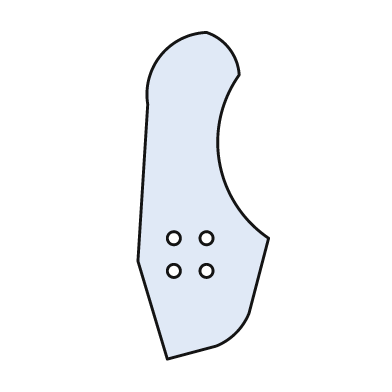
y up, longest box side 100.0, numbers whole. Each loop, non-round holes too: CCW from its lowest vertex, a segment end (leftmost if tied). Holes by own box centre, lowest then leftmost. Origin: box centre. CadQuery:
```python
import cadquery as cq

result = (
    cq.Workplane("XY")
    .moveTo(-11.0, -50.0)
    .lineTo(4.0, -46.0)
    .threePointArc((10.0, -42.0), (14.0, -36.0))
    .lineTo(20.0, -13.0)
    .threePointArc((5.0, 10.0), (11.0, 37.0))
    .threePointArc((8.0, 45.0), (1.0, 50.0))
    .threePointArc((-13.0, 43.0), (-17.0, 28.0))
    .lineTo(-20.0, -20.0)
    .close()
    .moveTo(-9.0, -23.0)
    .circle(2.0)
    .moveTo(1.0, -23.0)
    .circle(2.0)
    .moveTo(-9.0, -13.0)
    .circle(2.0)
    .moveTo(1.0, -13.0)
    .circle(2.0)
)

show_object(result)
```